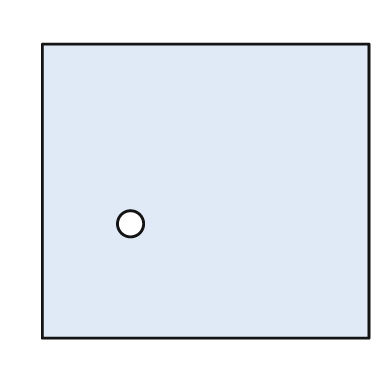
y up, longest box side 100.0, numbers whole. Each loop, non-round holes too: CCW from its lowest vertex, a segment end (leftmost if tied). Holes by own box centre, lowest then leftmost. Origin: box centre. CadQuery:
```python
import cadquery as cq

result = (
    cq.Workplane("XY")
    .moveTo(-50.0, -45.0)
    .lineTo(50.0, -45.0)
    .lineTo(50.0, 45.0)
    .lineTo(-50.0, 45.0)
    .close()
    .moveTo(-23.0, -10.0)
    .circle(4.0)
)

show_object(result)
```